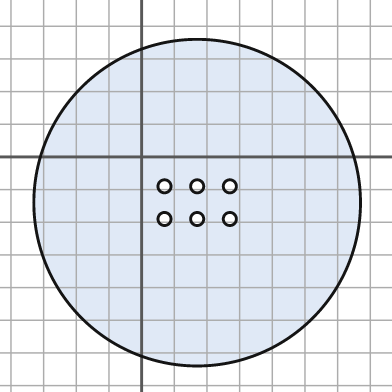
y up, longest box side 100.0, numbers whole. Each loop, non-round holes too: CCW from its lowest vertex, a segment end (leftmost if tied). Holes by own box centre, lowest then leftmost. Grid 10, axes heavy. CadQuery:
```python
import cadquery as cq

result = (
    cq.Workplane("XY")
    .moveTo(17.0, -14.0)
    .circle(50.0)
    .moveTo(7.0, -19.0)
    .circle(2.0)
    .moveTo(17.0, -19.0)
    .circle(2.0)
    .moveTo(27.0, -19.0)
    .circle(2.0)
    .moveTo(7.0, -9.0)
    .circle(2.0)
    .moveTo(17.0, -9.0)
    .circle(2.0)
    .moveTo(27.0, -9.0)
    .circle(2.0)
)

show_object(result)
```